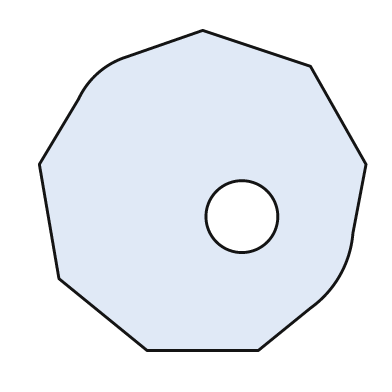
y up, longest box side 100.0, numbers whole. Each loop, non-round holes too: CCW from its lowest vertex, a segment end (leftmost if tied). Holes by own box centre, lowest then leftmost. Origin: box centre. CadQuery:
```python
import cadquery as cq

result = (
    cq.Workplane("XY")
    .moveTo(-17.0, -49.0)
    .lineTo(17.0, -49.0)
    .lineTo(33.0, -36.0)
    .threePointArc((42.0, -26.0), (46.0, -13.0))
    .lineTo(50.0, 8.0)
    .lineTo(33.0, 38.0)
    .lineTo(0.0, 49.0)
    .lineTo(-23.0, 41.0)
    .threePointArc((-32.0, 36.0), (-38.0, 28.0))
    .lineTo(-50.0, 8.0)
    .lineTo(-44.0, -27.0)
    .close()
    .moveTo(12.0, -8.0)
    .circle(11.0)
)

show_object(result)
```